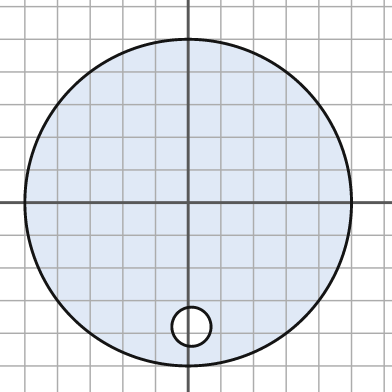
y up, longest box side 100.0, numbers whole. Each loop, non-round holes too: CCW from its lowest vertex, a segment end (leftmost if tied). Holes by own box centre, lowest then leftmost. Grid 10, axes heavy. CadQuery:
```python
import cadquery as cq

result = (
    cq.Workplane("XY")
    .moveTo(0.0, 0.0)
    .circle(50.0)
    .moveTo(1.0, -38.0)
    .circle(6.0)
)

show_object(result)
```